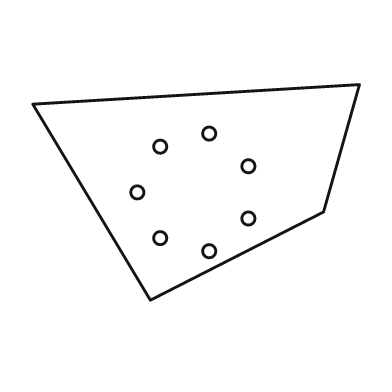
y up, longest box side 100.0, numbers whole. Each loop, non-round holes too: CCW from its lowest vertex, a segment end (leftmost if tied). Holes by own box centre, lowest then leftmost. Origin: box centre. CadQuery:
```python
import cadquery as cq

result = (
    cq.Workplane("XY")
    .moveTo(-14.0, -33.0)
    .lineTo(39.0, -6.0)
    .lineTo(50.0, 33.0)
    .lineTo(-50.0, 27.0)
    .close()
    .moveTo(4.0, -18.0)
    .circle(2.0)
    .moveTo(-11.0, -14.0)
    .circle(2.0)
    .moveTo(16.0, -8.0)
    .circle(2.0)
    .moveTo(-18.0, 0.0)
    .circle(2.0)
    .moveTo(16.0, 8.0)
    .circle(2.0)
    .moveTo(-11.0, 14.0)
    .circle(2.0)
    .moveTo(4.0, 18.0)
    .circle(2.0)
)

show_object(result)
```